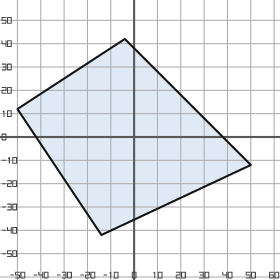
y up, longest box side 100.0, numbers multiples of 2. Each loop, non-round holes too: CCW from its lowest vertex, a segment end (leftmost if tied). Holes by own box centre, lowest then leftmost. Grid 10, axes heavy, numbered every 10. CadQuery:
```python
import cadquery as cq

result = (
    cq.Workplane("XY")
    .moveTo(-14.0, -42.0)
    .lineTo(50.0, -12.0)
    .lineTo(-4.0, 42.0)
    .lineTo(-50.0, 12.0)
    .close()
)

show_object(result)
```